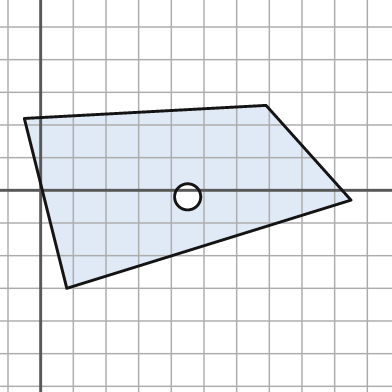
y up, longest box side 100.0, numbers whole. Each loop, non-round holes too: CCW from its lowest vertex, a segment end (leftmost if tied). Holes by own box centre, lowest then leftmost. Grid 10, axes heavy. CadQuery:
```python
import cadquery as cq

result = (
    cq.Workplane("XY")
    .moveTo(8.0, -30.0)
    .lineTo(95.0, -3.0)
    .lineTo(69.0, 26.0)
    .lineTo(-5.0, 22.0)
    .close()
    .moveTo(45.0, -2.0)
    .circle(4.0)
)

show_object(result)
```